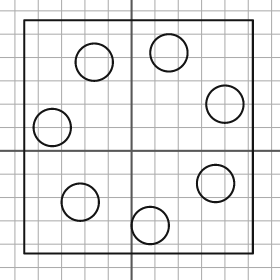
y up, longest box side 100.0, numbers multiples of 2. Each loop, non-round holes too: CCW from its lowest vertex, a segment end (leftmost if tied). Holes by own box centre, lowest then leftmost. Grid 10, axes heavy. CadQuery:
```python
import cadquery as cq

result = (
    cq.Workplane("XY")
    .moveTo(-46.0, -44.0)
    .lineTo(52.0, -44.0)
    .lineTo(52.0, 56.0)
    .lineTo(-46.0, 56.0)
    .close()
    .moveTo(8.0, -32.0)
    .circle(8.0)
    .moveTo(-22.0, -22.0)
    .circle(8.0)
    .moveTo(36.0, -14.0)
    .circle(8.0)
    .moveTo(-34.0, 10.0)
    .circle(8.0)
    .moveTo(40.0, 20.0)
    .circle(8.0)
    .moveTo(-16.0, 38.0)
    .circle(8.0)
    .moveTo(16.0, 42.0)
    .circle(8.0)
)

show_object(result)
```